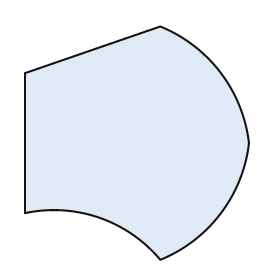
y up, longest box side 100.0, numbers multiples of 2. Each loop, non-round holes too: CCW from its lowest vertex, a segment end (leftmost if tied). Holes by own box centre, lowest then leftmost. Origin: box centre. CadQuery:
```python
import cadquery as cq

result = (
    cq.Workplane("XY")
    .moveTo(10.0, -50.0)
    .threePointArc((36.0, -30.0), (48.0, 0.0))
    .threePointArc((36.0, 30.0), (10.0, 50.0))
    .lineTo(-48.0, 30.0)
    .lineTo(-48.0, -30.0)
    .threePointArc((-16.0, -32.0), (10.0, -50.0))
    .close()
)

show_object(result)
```